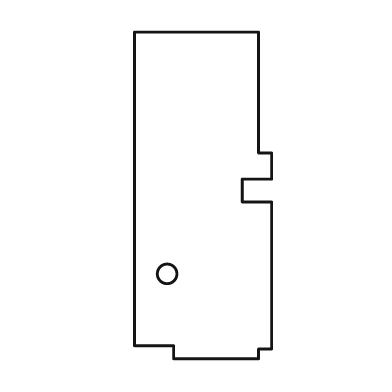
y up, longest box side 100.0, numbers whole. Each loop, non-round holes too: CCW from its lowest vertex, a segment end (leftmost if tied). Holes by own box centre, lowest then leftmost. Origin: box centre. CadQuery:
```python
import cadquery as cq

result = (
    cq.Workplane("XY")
    .moveTo(-9.0, -50.0)
    .lineTo(17.0, -50.0)
    .lineTo(17.0, -47.0)
    .lineTo(21.0, -47.0)
    .lineTo(21.0, -2.0)
    .lineTo(12.0, -2.0)
    .lineTo(12.0, 5.0)
    .lineTo(21.0, 5.0)
    .lineTo(21.0, 13.0)
    .lineTo(17.0, 13.0)
    .lineTo(17.0, 50.0)
    .lineTo(-21.0, 50.0)
    .lineTo(-21.0, -46.0)
    .lineTo(-9.0, -46.0)
    .close()
    .moveTo(-11.0, -24.0)
    .circle(3.0)
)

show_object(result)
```